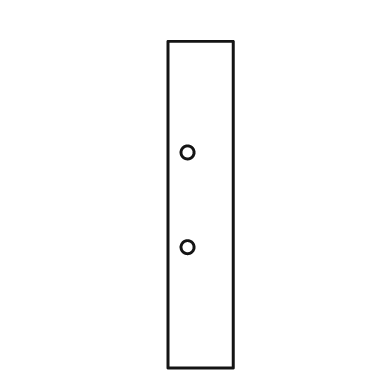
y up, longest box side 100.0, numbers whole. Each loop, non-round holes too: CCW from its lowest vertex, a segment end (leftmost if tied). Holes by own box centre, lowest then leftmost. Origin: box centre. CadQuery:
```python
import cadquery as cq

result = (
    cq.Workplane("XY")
    .moveTo(-10.0, -50.0)
    .lineTo(10.0, -50.0)
    .lineTo(10.0, 50.0)
    .lineTo(-10.0, 50.0)
    .close()
    .moveTo(-4.0, -13.0)
    .circle(2.0)
    .moveTo(-4.0, 16.0)
    .circle(2.0)
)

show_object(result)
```